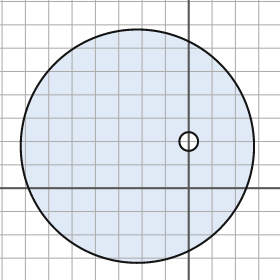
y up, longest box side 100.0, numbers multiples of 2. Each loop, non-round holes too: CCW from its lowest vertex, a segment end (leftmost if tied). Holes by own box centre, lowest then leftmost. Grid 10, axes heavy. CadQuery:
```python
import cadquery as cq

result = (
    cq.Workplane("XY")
    .moveTo(-22.0, 18.0)
    .circle(50.0)
    .moveTo(0.0, 20.0)
    .circle(4.0)
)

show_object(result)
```